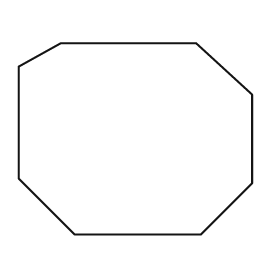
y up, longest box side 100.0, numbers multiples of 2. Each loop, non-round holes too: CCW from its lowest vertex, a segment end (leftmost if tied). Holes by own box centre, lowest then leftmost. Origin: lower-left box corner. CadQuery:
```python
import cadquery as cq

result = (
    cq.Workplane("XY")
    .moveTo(24.0, 0.0)
    .lineTo(78.0, 0.0)
    .lineTo(100.0, 22.0)
    .lineTo(100.0, 60.0)
    .lineTo(76.0, 82.0)
    .lineTo(18.0, 82.0)
    .lineTo(0.0, 72.0)
    .lineTo(0.0, 24.0)
    .close()
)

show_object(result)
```